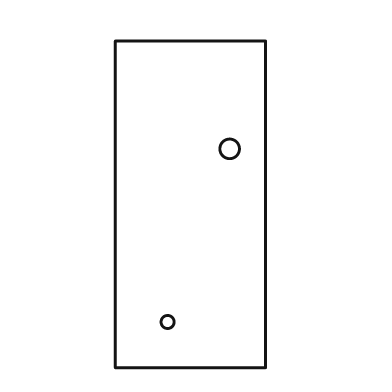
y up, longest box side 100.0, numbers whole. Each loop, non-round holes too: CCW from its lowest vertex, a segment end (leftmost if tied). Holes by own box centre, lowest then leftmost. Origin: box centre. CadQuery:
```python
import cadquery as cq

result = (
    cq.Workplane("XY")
    .moveTo(-23.0, -50.0)
    .lineTo(23.0, -50.0)
    .lineTo(23.0, 50.0)
    .lineTo(-23.0, 50.0)
    .close()
    .moveTo(-7.0, -36.0)
    .circle(2.0)
    .moveTo(12.0, 17.0)
    .circle(3.0)
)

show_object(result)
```